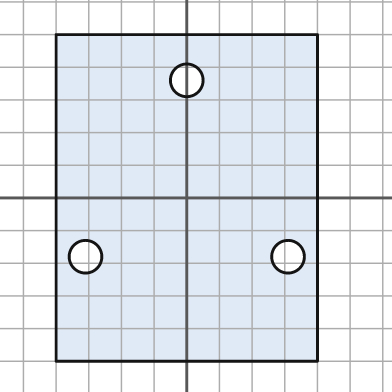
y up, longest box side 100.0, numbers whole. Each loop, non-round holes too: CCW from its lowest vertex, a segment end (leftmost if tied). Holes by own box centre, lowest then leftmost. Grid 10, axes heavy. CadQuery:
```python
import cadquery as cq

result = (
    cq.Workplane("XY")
    .moveTo(-40.0, -50.0)
    .lineTo(40.0, -50.0)
    .lineTo(40.0, 50.0)
    .lineTo(-40.0, 50.0)
    .close()
    .moveTo(-31.0, -18.0)
    .circle(5.0)
    .moveTo(31.0, -18.0)
    .circle(5.0)
    .moveTo(0.0, 36.0)
    .circle(5.0)
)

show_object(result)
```